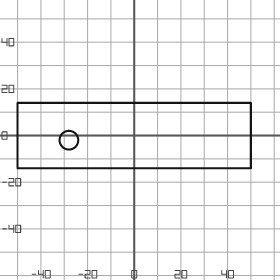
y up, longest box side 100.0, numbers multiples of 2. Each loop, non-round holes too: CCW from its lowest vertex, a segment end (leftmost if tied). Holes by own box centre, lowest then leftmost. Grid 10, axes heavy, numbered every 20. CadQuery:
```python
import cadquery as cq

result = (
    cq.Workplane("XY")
    .moveTo(-50.0, -14.0)
    .lineTo(50.0, -14.0)
    .lineTo(50.0, 14.0)
    .lineTo(-50.0, 14.0)
    .close()
    .moveTo(-28.0, -2.0)
    .circle(4.0)
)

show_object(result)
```